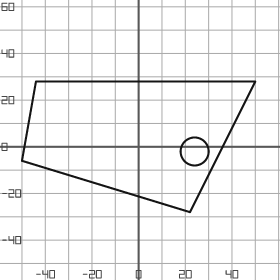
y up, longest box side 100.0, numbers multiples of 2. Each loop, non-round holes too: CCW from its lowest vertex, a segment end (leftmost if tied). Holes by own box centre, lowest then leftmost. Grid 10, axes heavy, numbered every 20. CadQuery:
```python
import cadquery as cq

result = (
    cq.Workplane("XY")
    .moveTo(22.0, -28.0)
    .lineTo(50.0, 28.0)
    .lineTo(-44.0, 28.0)
    .lineTo(-50.0, -6.0)
    .close()
    .moveTo(24.0, -2.0)
    .circle(6.0)
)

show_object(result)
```